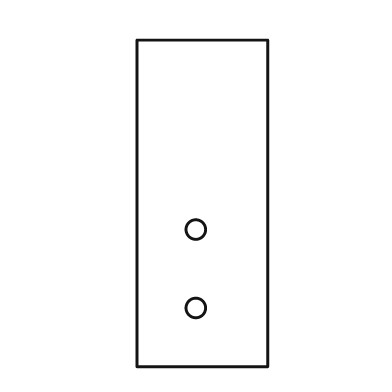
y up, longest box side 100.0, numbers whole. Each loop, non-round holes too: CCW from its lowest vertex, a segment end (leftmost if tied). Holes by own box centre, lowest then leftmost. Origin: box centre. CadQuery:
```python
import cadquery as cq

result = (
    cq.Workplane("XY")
    .moveTo(-20.0, -50.0)
    .lineTo(20.0, -50.0)
    .lineTo(20.0, 50.0)
    .lineTo(-20.0, 50.0)
    .close()
    .moveTo(-2.0, -32.0)
    .circle(3.0)
    .moveTo(-2.0, -8.0)
    .circle(3.0)
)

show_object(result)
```